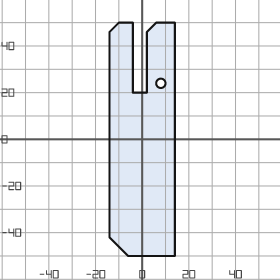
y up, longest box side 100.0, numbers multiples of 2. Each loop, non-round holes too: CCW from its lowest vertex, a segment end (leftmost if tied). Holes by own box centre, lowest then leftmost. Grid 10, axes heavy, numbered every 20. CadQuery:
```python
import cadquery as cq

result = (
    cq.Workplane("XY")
    .moveTo(-6.0, -50.0)
    .lineTo(14.0, -50.0)
    .lineTo(14.0, 50.0)
    .lineTo(6.0, 50.0)
    .lineTo(2.0, 46.0)
    .lineTo(2.0, 20.0)
    .lineTo(-4.0, 20.0)
    .lineTo(-4.0, 50.0)
    .lineTo(-10.0, 50.0)
    .lineTo(-14.0, 46.0)
    .lineTo(-14.0, -42.0)
    .close()
    .moveTo(8.0, 24.0)
    .circle(2.0)
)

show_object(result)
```